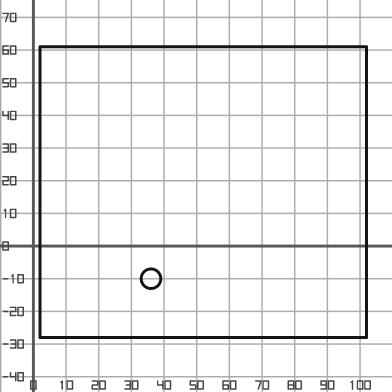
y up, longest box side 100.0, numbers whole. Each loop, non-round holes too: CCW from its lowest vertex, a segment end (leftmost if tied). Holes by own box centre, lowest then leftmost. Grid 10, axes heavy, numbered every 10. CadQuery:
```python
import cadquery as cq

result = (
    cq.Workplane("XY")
    .moveTo(2.0, -28.0)
    .lineTo(102.0, -28.0)
    .lineTo(102.0, 61.0)
    .lineTo(2.0, 61.0)
    .close()
    .moveTo(36.0, -10.0)
    .circle(3.0)
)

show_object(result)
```